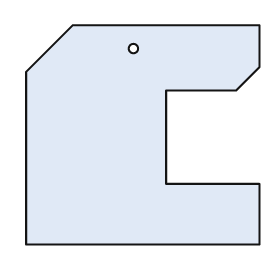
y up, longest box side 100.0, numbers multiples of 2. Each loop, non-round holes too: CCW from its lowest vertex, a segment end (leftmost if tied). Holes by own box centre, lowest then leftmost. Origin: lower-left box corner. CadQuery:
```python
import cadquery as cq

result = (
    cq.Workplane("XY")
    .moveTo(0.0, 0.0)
    .lineTo(100.0, 0.0)
    .lineTo(100.0, 26.0)
    .lineTo(60.0, 26.0)
    .lineTo(60.0, 66.0)
    .lineTo(90.0, 66.0)
    .lineTo(100.0, 76.0)
    .lineTo(100.0, 94.0)
    .lineTo(20.0, 94.0)
    .lineTo(0.0, 74.0)
    .close()
    .moveTo(46.0, 84.0)
    .circle(2.0)
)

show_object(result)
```